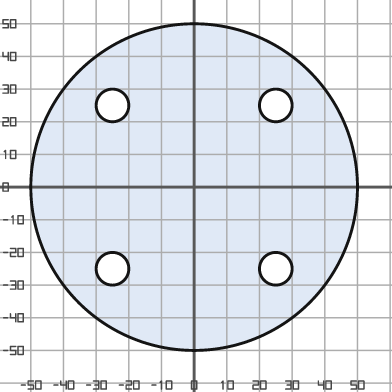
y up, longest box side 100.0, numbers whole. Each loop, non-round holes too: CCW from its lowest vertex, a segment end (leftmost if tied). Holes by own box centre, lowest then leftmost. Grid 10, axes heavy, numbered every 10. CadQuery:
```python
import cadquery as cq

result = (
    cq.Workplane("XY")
    .moveTo(0.0, 0.0)
    .circle(50.0)
    .moveTo(-25.0, -25.0)
    .circle(5.0)
    .moveTo(25.0, -25.0)
    .circle(5.0)
    .moveTo(-25.0, 25.0)
    .circle(5.0)
    .moveTo(25.0, 25.0)
    .circle(5.0)
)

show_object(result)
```